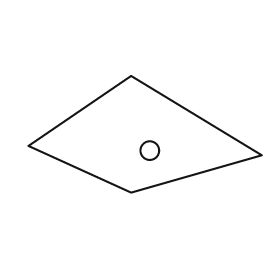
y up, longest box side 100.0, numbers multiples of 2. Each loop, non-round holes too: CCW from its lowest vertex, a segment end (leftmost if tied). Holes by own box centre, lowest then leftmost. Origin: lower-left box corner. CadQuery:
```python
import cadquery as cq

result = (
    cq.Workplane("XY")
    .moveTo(44.0, 0.0)
    .lineTo(100.0, 16.0)
    .lineTo(44.0, 50.0)
    .lineTo(0.0, 20.0)
    .close()
    .moveTo(52.0, 18.0)
    .circle(4.0)
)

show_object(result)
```